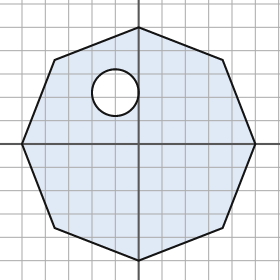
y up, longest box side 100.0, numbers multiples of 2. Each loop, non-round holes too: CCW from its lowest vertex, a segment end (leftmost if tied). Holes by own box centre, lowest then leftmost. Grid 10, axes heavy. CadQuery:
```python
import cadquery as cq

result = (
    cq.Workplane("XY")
    .moveTo(0.0, -50.0)
    .lineTo(36.0, -36.0)
    .lineTo(50.0, 0.0)
    .lineTo(36.0, 36.0)
    .lineTo(0.0, 50.0)
    .lineTo(-36.0, 36.0)
    .lineTo(-50.0, 0.0)
    .lineTo(-36.0, -36.0)
    .close()
    .moveTo(-10.0, 22.0)
    .circle(10.0)
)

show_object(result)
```